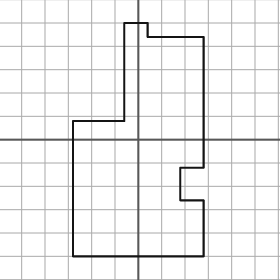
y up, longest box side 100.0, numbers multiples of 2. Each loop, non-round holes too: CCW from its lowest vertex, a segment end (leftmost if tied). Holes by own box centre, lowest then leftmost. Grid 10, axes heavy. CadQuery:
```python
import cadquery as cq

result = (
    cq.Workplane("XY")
    .moveTo(-28.0, -50.0)
    .lineTo(28.0, -50.0)
    .lineTo(28.0, -26.0)
    .lineTo(18.0, -26.0)
    .lineTo(18.0, -12.0)
    .lineTo(28.0, -12.0)
    .lineTo(28.0, 44.0)
    .lineTo(4.0, 44.0)
    .lineTo(4.0, 50.0)
    .lineTo(-6.0, 50.0)
    .lineTo(-6.0, 8.0)
    .lineTo(-28.0, 8.0)
    .close()
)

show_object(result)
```